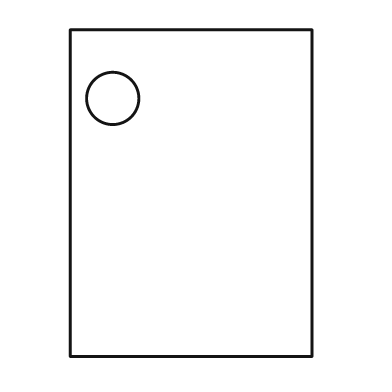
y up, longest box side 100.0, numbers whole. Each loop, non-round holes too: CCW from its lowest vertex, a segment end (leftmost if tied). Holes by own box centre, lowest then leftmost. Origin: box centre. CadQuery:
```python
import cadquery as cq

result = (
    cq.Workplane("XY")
    .moveTo(-37.0, -50.0)
    .lineTo(37.0, -50.0)
    .lineTo(37.0, 50.0)
    .lineTo(-37.0, 50.0)
    .close()
    .moveTo(-24.0, 29.0)
    .circle(8.0)
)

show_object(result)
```